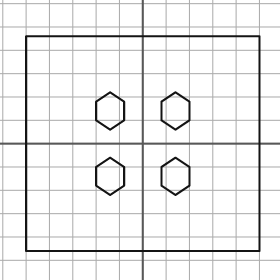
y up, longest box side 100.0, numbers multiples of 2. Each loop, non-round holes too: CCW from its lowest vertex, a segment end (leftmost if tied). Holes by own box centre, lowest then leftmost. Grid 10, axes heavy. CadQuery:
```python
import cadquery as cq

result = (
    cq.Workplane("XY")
    .moveTo(-50.0, -46.0)
    .lineTo(50.0, -46.0)
    .lineTo(50.0, 46.0)
    .lineTo(-50.0, 46.0)
    .close()
    .moveTo(-14.0, -22.0)
    .lineTo(-8.0, -18.0)
    .lineTo(-8.0, -10.0)
    .lineTo(-14.0, -6.0)
    .lineTo(-20.0, -10.0)
    .lineTo(-20.0, -18.0)
    .close()
    .moveTo(14.0, -22.0)
    .lineTo(20.0, -18.0)
    .lineTo(20.0, -10.0)
    .lineTo(14.0, -6.0)
    .lineTo(8.0, -10.0)
    .lineTo(8.0, -18.0)
    .close()
    .moveTo(-14.0, 6.0)
    .lineTo(-8.0, 10.0)
    .lineTo(-8.0, 18.0)
    .lineTo(-14.0, 22.0)
    .lineTo(-20.0, 18.0)
    .lineTo(-20.0, 10.0)
    .close()
    .moveTo(14.0, 6.0)
    .lineTo(20.0, 10.0)
    .lineTo(20.0, 18.0)
    .lineTo(14.0, 22.0)
    .lineTo(8.0, 18.0)
    .lineTo(8.0, 10.0)
    .close()
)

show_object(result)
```